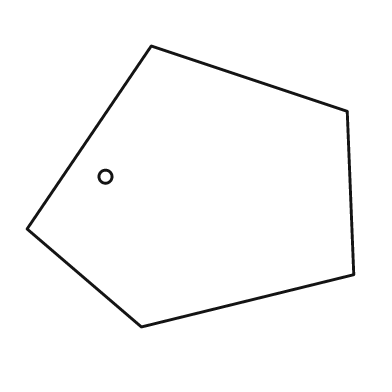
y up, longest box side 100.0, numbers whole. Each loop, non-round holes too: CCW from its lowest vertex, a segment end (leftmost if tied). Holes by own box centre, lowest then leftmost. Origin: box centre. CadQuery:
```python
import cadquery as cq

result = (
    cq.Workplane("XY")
    .moveTo(-15.0, -43.0)
    .lineTo(50.0, -27.0)
    .lineTo(48.0, 23.0)
    .lineTo(-12.0, 43.0)
    .lineTo(-50.0, -13.0)
    .close()
    .moveTo(-26.0, 3.0)
    .circle(2.0)
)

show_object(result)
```